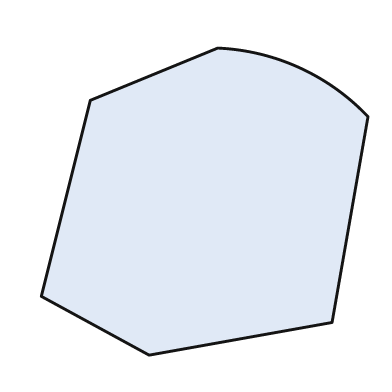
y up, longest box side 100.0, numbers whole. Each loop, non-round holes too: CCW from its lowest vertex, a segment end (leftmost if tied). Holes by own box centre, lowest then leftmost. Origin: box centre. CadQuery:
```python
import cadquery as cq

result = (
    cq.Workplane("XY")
    .moveTo(-17.0, -47.0)
    .lineTo(39.0, -37.0)
    .lineTo(50.0, 26.0)
    .threePointArc((29.0, 41.0), (4.0, 47.0))
    .lineTo(-35.0, 31.0)
    .lineTo(-50.0, -29.0)
    .close()
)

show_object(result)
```